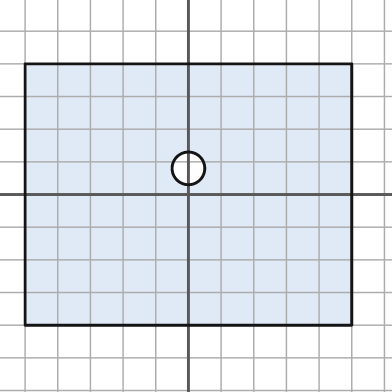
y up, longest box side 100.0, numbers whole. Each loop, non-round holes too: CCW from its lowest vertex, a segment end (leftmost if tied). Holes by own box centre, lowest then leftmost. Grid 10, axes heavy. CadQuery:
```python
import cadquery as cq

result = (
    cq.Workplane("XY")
    .moveTo(-50.0, -40.0)
    .lineTo(50.0, -40.0)
    .lineTo(50.0, 40.0)
    .lineTo(-50.0, 40.0)
    .close()
    .moveTo(0.0, 8.0)
    .circle(5.0)
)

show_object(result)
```